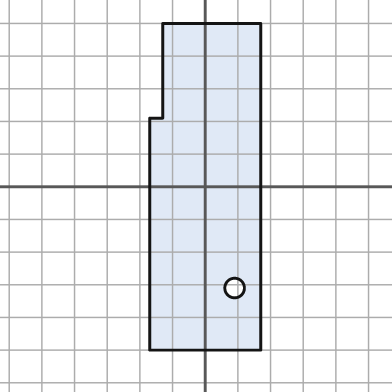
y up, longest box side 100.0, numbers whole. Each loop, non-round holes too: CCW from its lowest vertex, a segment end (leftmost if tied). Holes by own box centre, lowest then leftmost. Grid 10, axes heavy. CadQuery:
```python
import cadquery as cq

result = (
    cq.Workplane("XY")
    .moveTo(-17.0, -50.0)
    .lineTo(17.0, -50.0)
    .lineTo(17.0, 50.0)
    .lineTo(-13.0, 50.0)
    .lineTo(-13.0, 21.0)
    .lineTo(-17.0, 21.0)
    .close()
    .moveTo(9.0, -31.0)
    .circle(3.0)
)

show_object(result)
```